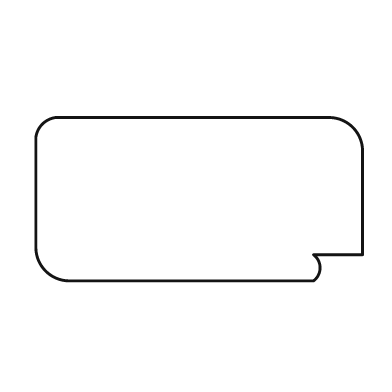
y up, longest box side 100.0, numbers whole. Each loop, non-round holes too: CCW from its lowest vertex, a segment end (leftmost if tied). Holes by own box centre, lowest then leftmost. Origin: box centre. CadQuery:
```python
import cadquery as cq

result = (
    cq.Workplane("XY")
    .moveTo(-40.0, -25.0)
    .lineTo(35.0, -25.0)
    .threePointArc((37.0, -21.0), (35.0, -17.0))
    .lineTo(50.0, -17.0)
    .lineTo(50.0, 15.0)
    .threePointArc((47.0, 22.0), (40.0, 25.0))
    .lineTo(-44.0, 25.0)
    .threePointArc((-48.0, 23.0), (-50.0, 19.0))
    .lineTo(-50.0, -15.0)
    .threePointArc((-47.0, -22.0), (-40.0, -25.0))
    .close()
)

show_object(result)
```